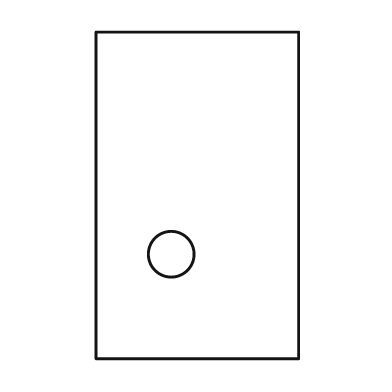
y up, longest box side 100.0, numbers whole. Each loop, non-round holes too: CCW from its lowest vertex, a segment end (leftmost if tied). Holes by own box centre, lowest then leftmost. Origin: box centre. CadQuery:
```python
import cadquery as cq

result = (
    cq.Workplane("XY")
    .moveTo(-31.0, -50.0)
    .lineTo(31.0, -50.0)
    .lineTo(31.0, 50.0)
    .lineTo(-31.0, 50.0)
    .close()
    .moveTo(-8.0, -18.0)
    .circle(7.0)
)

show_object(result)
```